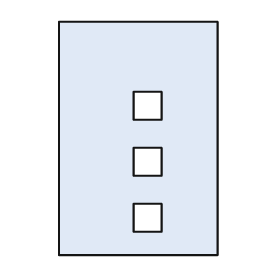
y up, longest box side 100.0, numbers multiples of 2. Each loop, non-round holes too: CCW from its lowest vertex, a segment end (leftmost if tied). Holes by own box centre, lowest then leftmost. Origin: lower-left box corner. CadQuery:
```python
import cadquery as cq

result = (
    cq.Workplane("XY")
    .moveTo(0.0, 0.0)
    .lineTo(68.0, 0.0)
    .lineTo(68.0, 100.0)
    .lineTo(0.0, 100.0)
    .close()
    .moveTo(32.0, 10.0)
    .lineTo(44.0, 10.0)
    .lineTo(44.0, 22.0)
    .lineTo(32.0, 22.0)
    .close()
    .moveTo(32.0, 34.0)
    .lineTo(44.0, 34.0)
    .lineTo(44.0, 46.0)
    .lineTo(32.0, 46.0)
    .close()
    .moveTo(32.0, 58.0)
    .lineTo(44.0, 58.0)
    .lineTo(44.0, 70.0)
    .lineTo(32.0, 70.0)
    .close()
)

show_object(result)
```